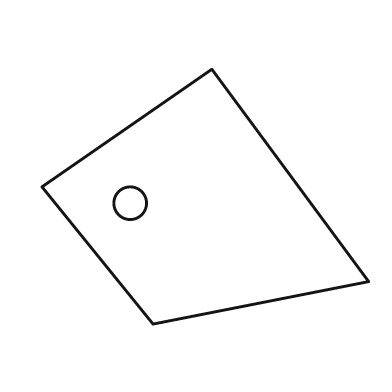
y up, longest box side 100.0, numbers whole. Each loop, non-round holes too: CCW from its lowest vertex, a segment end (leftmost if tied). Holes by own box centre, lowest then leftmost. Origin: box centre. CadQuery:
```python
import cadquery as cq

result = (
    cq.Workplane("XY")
    .moveTo(-16.0, -39.0)
    .lineTo(50.0, -26.0)
    .lineTo(2.0, 39.0)
    .lineTo(-50.0, 3.0)
    .close()
    .moveTo(-23.0, -2.0)
    .circle(5.0)
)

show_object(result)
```